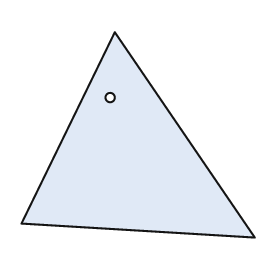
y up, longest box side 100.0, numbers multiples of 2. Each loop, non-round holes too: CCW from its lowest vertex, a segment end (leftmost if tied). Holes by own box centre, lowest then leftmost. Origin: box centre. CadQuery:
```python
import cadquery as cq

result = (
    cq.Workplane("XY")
    .moveTo(50.0, -44.0)
    .lineTo(-10.0, 44.0)
    .lineTo(-50.0, -38.0)
    .close()
    .moveTo(-12.0, 16.0)
    .circle(2.0)
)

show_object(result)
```